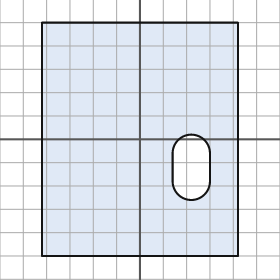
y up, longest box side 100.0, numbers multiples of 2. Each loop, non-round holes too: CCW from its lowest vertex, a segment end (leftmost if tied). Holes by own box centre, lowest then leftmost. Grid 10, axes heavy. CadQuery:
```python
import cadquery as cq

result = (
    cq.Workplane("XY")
    .moveTo(-42.0, -50.0)
    .lineTo(42.0, -50.0)
    .lineTo(42.0, 50.0)
    .lineTo(-42.0, 50.0)
    .close()
    .moveTo(14.0, -18.0)
    .threePointArc((22.0, -26.0), (30.0, -18.0))
    .lineTo(30.0, -6.0)
    .threePointArc((22.0, 2.0), (14.0, -6.0))
    .close()
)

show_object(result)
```